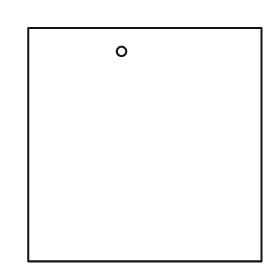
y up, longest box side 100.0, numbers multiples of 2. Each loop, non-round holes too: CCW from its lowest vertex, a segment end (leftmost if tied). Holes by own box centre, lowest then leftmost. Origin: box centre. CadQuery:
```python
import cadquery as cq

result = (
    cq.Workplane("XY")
    .moveTo(-50.0, -50.0)
    .lineTo(50.0, -50.0)
    .lineTo(50.0, 50.0)
    .lineTo(-50.0, 50.0)
    .close()
    .moveTo(-10.0, 40.0)
    .circle(2.0)
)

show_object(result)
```